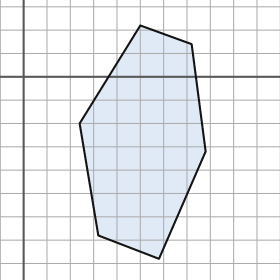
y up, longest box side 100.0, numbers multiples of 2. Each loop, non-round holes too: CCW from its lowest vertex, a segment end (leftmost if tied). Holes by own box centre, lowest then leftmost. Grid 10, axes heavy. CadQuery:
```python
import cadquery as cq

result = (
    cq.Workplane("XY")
    .moveTo(58.0, -78.0)
    .lineTo(78.0, -32.0)
    .lineTo(72.0, 14.0)
    .lineTo(50.0, 22.0)
    .lineTo(24.0, -20.0)
    .lineTo(32.0, -68.0)
    .close()
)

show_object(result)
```